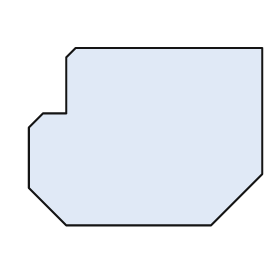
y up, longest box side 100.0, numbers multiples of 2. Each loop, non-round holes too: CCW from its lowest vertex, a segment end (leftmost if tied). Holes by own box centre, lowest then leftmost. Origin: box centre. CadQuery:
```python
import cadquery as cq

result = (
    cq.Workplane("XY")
    .moveTo(-34.0, -38.0)
    .lineTo(28.0, -38.0)
    .lineTo(50.0, -16.0)
    .lineTo(50.0, 38.0)
    .lineTo(-30.0, 38.0)
    .lineTo(-34.0, 34.0)
    .lineTo(-34.0, 10.0)
    .lineTo(-44.0, 10.0)
    .lineTo(-50.0, 4.0)
    .lineTo(-50.0, -22.0)
    .close()
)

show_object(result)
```